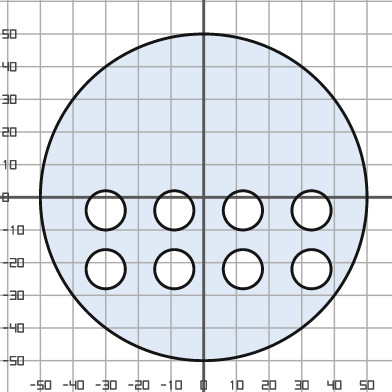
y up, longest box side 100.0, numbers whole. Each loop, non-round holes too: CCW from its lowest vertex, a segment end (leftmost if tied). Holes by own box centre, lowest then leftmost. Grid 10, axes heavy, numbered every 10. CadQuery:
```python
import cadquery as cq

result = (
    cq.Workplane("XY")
    .moveTo(0.0, 0.0)
    .circle(50.0)
    .moveTo(-30.0, -22.0)
    .circle(6.0)
    .moveTo(-9.0, -22.0)
    .circle(6.0)
    .moveTo(12.0, -22.0)
    .circle(6.0)
    .moveTo(33.0, -22.0)
    .circle(6.0)
    .moveTo(-30.0, -4.0)
    .circle(6.0)
    .moveTo(-9.0, -4.0)
    .circle(6.0)
    .moveTo(12.0, -4.0)
    .circle(6.0)
    .moveTo(33.0, -4.0)
    .circle(6.0)
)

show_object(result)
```